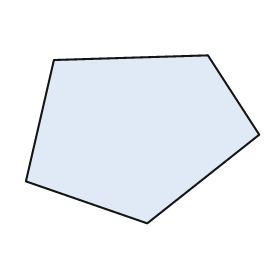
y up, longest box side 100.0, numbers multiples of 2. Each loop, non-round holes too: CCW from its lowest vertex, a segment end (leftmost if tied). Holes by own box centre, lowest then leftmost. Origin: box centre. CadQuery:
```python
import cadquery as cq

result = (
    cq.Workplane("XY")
    .moveTo(2.0, -36.0)
    .lineTo(50.0, 2.0)
    .lineTo(28.0, 36.0)
    .lineTo(-38.0, 34.0)
    .lineTo(-50.0, -18.0)
    .close()
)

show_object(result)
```